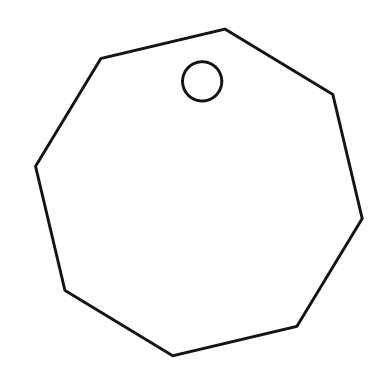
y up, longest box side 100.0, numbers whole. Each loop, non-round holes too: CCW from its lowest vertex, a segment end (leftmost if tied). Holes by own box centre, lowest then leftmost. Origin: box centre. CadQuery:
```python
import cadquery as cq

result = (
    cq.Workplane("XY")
    .moveTo(-8.0, -50.0)
    .lineTo(30.0, -41.0)
    .lineTo(50.0, -8.0)
    .lineTo(41.0, 30.0)
    .lineTo(8.0, 50.0)
    .lineTo(-30.0, 41.0)
    .lineTo(-50.0, 8.0)
    .lineTo(-41.0, -30.0)
    .close()
    .moveTo(1.0, 34.0)
    .circle(6.0)
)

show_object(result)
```